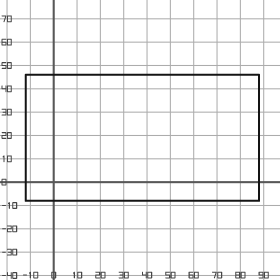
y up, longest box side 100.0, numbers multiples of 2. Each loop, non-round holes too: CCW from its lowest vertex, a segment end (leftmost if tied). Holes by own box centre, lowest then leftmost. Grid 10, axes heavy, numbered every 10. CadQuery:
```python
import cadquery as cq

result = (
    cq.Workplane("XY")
    .moveTo(-12.0, -8.0)
    .lineTo(88.0, -8.0)
    .lineTo(88.0, 46.0)
    .lineTo(-12.0, 46.0)
    .close()
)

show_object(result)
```